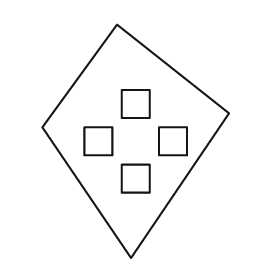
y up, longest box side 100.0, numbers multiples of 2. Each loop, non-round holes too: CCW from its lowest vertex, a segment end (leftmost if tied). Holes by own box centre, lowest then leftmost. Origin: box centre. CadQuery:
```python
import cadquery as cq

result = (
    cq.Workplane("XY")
    .moveTo(-2.0, -50.0)
    .lineTo(40.0, 12.0)
    .lineTo(-8.0, 50.0)
    .lineTo(-40.0, 6.0)
    .close()
    .moveTo(-6.0, -22.0)
    .lineTo(6.0, -22.0)
    .lineTo(6.0, -10.0)
    .lineTo(-6.0, -10.0)
    .close()
    .moveTo(-22.0, -6.0)
    .lineTo(-10.0, -6.0)
    .lineTo(-10.0, 6.0)
    .lineTo(-22.0, 6.0)
    .close()
    .moveTo(10.0, -6.0)
    .lineTo(22.0, -6.0)
    .lineTo(22.0, 6.0)
    .lineTo(10.0, 6.0)
    .close()
    .moveTo(-6.0, 10.0)
    .lineTo(6.0, 10.0)
    .lineTo(6.0, 22.0)
    .lineTo(-6.0, 22.0)
    .close()
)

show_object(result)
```